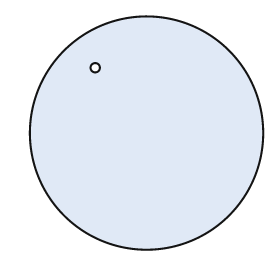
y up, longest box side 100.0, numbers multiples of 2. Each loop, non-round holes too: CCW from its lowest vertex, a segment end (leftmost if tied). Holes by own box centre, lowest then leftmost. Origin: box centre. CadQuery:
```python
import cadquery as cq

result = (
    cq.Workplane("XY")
    .moveTo(0.0, 0.0)
    .circle(50.0)
    .moveTo(-22.0, 28.0)
    .circle(2.0)
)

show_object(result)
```